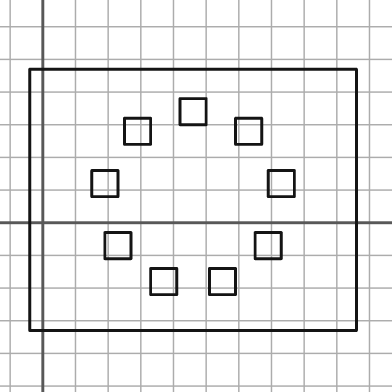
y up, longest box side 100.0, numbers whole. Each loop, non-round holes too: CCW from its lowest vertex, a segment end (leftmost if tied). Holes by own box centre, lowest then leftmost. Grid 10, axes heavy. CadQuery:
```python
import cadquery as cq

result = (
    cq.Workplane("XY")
    .moveTo(-4.0, -33.0)
    .lineTo(96.0, -33.0)
    .lineTo(96.0, 47.0)
    .lineTo(-4.0, 47.0)
    .close()
    .moveTo(33.0, -22.0)
    .lineTo(41.0, -22.0)
    .lineTo(41.0, -14.0)
    .lineTo(33.0, -14.0)
    .close()
    .moveTo(51.0, -22.0)
    .lineTo(59.0, -22.0)
    .lineTo(59.0, -14.0)
    .lineTo(51.0, -14.0)
    .close()
    .moveTo(19.0, -11.0)
    .lineTo(27.0, -11.0)
    .lineTo(27.0, -3.0)
    .lineTo(19.0, -3.0)
    .close()
    .moveTo(65.0, -11.0)
    .lineTo(73.0, -11.0)
    .lineTo(73.0, -3.0)
    .lineTo(65.0, -3.0)
    .close()
    .moveTo(15.0, 8.0)
    .lineTo(23.0, 8.0)
    .lineTo(23.0, 16.0)
    .lineTo(15.0, 16.0)
    .close()
    .moveTo(69.0, 8.0)
    .lineTo(77.0, 8.0)
    .lineTo(77.0, 16.0)
    .lineTo(69.0, 16.0)
    .close()
    .moveTo(25.0, 24.0)
    .lineTo(33.0, 24.0)
    .lineTo(33.0, 32.0)
    .lineTo(25.0, 32.0)
    .close()
    .moveTo(59.0, 24.0)
    .lineTo(67.0, 24.0)
    .lineTo(67.0, 32.0)
    .lineTo(59.0, 32.0)
    .close()
    .moveTo(42.0, 30.0)
    .lineTo(50.0, 30.0)
    .lineTo(50.0, 38.0)
    .lineTo(42.0, 38.0)
    .close()
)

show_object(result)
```